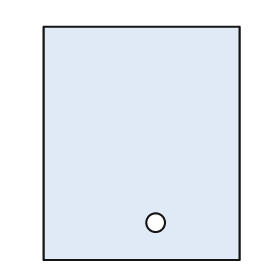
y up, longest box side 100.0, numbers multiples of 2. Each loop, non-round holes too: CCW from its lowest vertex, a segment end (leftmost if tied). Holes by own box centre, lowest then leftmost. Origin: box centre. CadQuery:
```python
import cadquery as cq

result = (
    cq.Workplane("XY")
    .moveTo(-42.0, -50.0)
    .lineTo(42.0, -50.0)
    .lineTo(42.0, 50.0)
    .lineTo(-42.0, 50.0)
    .close()
    .moveTo(6.0, -34.0)
    .circle(4.0)
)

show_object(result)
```